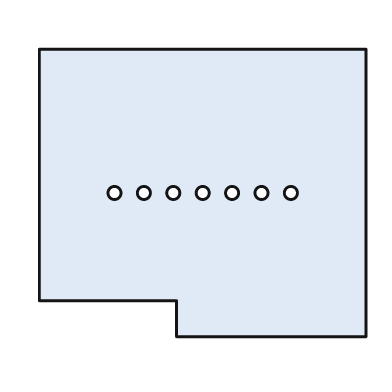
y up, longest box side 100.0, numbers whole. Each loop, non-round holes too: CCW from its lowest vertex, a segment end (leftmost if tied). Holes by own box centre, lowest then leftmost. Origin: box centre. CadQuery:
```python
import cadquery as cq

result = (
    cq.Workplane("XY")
    .moveTo(-8.0, -44.0)
    .lineTo(50.0, -44.0)
    .lineTo(50.0, 44.0)
    .lineTo(-50.0, 44.0)
    .lineTo(-50.0, -33.0)
    .lineTo(-8.0, -33.0)
    .close()
    .moveTo(-27.0, 0.0)
    .circle(2.0)
    .moveTo(-18.0, 0.0)
    .circle(2.0)
    .moveTo(-9.0, 0.0)
    .circle(2.0)
    .moveTo(0.0, 0.0)
    .circle(2.0)
    .moveTo(9.0, 0.0)
    .circle(2.0)
    .moveTo(18.0, 0.0)
    .circle(2.0)
    .moveTo(27.0, 0.0)
    .circle(2.0)
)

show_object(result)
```